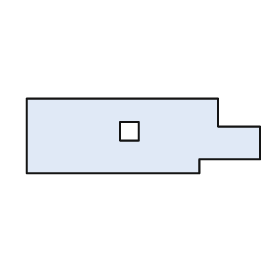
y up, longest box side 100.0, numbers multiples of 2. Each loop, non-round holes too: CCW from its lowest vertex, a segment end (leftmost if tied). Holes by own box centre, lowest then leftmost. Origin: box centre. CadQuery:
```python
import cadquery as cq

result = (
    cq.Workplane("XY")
    .moveTo(-50.0, -16.0)
    .lineTo(24.0, -16.0)
    .lineTo(24.0, -10.0)
    .lineTo(50.0, -10.0)
    .lineTo(50.0, 4.0)
    .lineTo(32.0, 4.0)
    .lineTo(32.0, 16.0)
    .lineTo(-50.0, 16.0)
    .close()
    .moveTo(-10.0, -2.0)
    .lineTo(-2.0, -2.0)
    .lineTo(-2.0, 6.0)
    .lineTo(-10.0, 6.0)
    .close()
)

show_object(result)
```